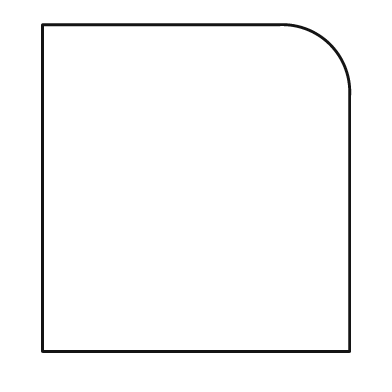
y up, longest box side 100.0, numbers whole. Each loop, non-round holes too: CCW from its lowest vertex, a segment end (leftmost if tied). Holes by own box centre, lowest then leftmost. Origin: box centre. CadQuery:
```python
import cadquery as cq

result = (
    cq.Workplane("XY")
    .moveTo(-47.0, -50.0)
    .lineTo(47.0, -50.0)
    .lineTo(47.0, 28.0)
    .threePointArc((41.0, 44.0), (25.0, 50.0))
    .lineTo(-47.0, 50.0)
    .close()
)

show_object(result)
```